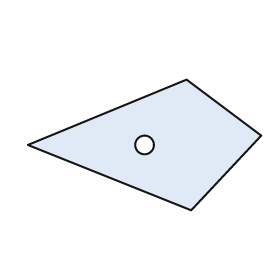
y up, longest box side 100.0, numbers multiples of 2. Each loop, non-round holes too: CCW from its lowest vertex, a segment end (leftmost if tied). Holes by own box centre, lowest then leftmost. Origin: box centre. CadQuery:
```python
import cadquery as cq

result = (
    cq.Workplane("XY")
    .moveTo(20.0, -28.0)
    .lineTo(50.0, 4.0)
    .lineTo(18.0, 28.0)
    .lineTo(-50.0, 0.0)
    .close()
    .moveTo(0.0, 0.0)
    .circle(4.0)
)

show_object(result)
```